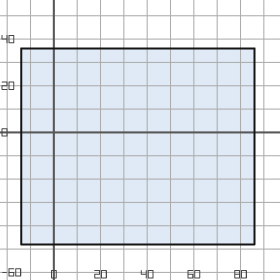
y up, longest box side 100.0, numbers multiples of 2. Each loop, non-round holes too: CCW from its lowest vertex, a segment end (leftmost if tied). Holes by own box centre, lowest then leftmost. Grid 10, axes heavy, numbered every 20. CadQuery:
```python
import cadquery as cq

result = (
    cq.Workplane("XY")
    .moveTo(-14.0, -48.0)
    .lineTo(86.0, -48.0)
    .lineTo(86.0, 36.0)
    .lineTo(-14.0, 36.0)
    .close()
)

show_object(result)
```